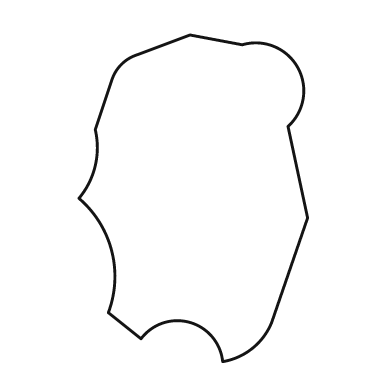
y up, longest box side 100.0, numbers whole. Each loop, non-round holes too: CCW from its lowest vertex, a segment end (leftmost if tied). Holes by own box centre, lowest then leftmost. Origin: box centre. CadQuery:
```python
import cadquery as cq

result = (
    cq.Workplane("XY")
    .moveTo(9.0, -50.0)
    .threePointArc((18.0, -46.0), (24.0, -38.0))
    .lineTo(35.0, -6.0)
    .lineTo(29.0, 22.0)
    .threePointArc((32.0, 40.0), (15.0, 47.0))
    .lineTo(-1.0, 50.0)
    .lineTo(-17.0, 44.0)
    .threePointArc((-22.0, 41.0), (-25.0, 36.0))
    .lineTo(-30.0, 21.0)
    .threePointArc((-30.0, 10.0), (-35.0, 0.0))
    .threePointArc((-25.0, -16.0), (-26.0, -35.0))
    .lineTo(-16.0, -43.0)
    .threePointArc((-1.0, -38.0), (9.0, -50.0))
    .close()
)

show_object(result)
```